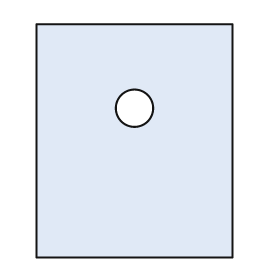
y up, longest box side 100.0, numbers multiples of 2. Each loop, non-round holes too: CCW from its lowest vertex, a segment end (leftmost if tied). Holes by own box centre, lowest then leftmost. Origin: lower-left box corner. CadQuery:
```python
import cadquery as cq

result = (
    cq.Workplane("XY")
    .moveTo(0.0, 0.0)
    .lineTo(84.0, 0.0)
    .lineTo(84.0, 100.0)
    .lineTo(0.0, 100.0)
    .close()
    .moveTo(42.0, 64.0)
    .circle(8.0)
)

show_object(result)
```